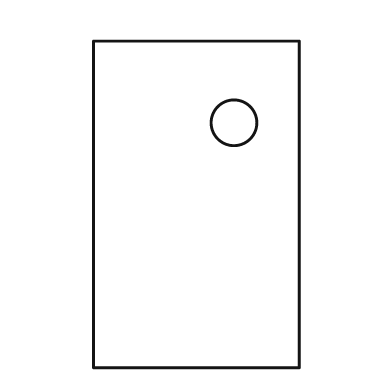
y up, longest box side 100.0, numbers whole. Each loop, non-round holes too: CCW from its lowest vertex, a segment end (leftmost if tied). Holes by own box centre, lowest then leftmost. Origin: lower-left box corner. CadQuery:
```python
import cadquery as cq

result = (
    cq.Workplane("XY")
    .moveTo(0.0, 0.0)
    .lineTo(63.0, 0.0)
    .lineTo(63.0, 100.0)
    .lineTo(0.0, 100.0)
    .close()
    .moveTo(43.0, 75.0)
    .circle(7.0)
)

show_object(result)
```